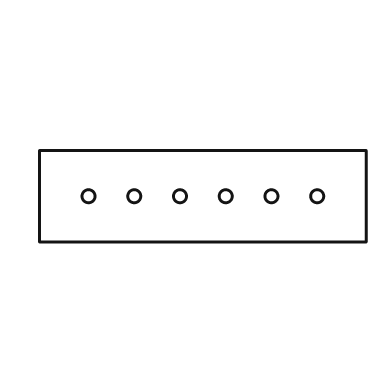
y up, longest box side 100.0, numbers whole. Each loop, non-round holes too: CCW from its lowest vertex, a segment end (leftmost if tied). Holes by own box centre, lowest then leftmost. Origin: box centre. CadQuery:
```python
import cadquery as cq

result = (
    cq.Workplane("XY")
    .moveTo(-50.0, -14.0)
    .lineTo(50.0, -14.0)
    .lineTo(50.0, 14.0)
    .lineTo(-50.0, 14.0)
    .close()
    .moveTo(-35.0, 0.0)
    .circle(2.0)
    .moveTo(-21.0, 0.0)
    .circle(2.0)
    .moveTo(-7.0, 0.0)
    .circle(2.0)
    .moveTo(7.0, 0.0)
    .circle(2.0)
    .moveTo(21.0, 0.0)
    .circle(2.0)
    .moveTo(35.0, 0.0)
    .circle(2.0)
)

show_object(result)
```